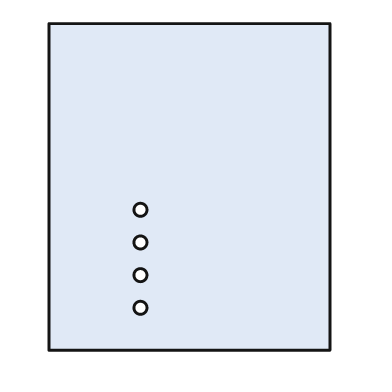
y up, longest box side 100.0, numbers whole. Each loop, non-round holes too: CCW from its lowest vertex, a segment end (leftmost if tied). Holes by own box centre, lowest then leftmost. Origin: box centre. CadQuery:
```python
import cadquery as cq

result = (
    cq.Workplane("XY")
    .moveTo(-43.0, -50.0)
    .lineTo(43.0, -50.0)
    .lineTo(43.0, 50.0)
    .lineTo(-43.0, 50.0)
    .close()
    .moveTo(-15.0, -37.0)
    .circle(2.0)
    .moveTo(-15.0, -27.0)
    .circle(2.0)
    .moveTo(-15.0, -17.0)
    .circle(2.0)
    .moveTo(-15.0, -7.0)
    .circle(2.0)
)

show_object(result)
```